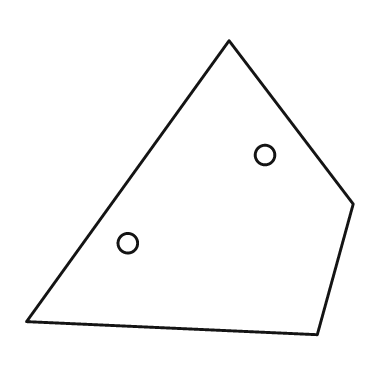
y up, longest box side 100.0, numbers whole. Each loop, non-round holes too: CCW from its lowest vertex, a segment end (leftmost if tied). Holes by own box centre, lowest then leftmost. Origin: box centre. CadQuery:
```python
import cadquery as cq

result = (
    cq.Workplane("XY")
    .moveTo(39.0, -45.0)
    .lineTo(50.0, -5.0)
    .lineTo(12.0, 45.0)
    .lineTo(-50.0, -41.0)
    .close()
    .moveTo(-19.0, -17.0)
    .circle(3.0)
    .moveTo(23.0, 10.0)
    .circle(3.0)
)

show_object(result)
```